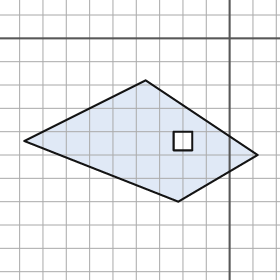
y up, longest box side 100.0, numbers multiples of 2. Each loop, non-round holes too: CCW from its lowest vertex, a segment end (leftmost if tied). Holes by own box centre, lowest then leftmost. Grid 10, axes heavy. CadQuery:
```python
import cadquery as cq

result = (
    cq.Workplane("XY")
    .moveTo(-22.0, -70.0)
    .lineTo(12.0, -50.0)
    .lineTo(-36.0, -18.0)
    .lineTo(-88.0, -44.0)
    .close()
    .moveTo(-24.0, -48.0)
    .lineTo(-16.0, -48.0)
    .lineTo(-16.0, -40.0)
    .lineTo(-24.0, -40.0)
    .close()
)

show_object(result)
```